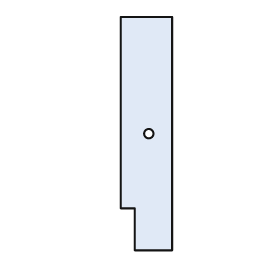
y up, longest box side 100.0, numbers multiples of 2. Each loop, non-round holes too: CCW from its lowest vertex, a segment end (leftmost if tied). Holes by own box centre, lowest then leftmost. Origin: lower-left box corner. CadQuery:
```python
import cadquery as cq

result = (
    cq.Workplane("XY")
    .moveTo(6.0, 0.0)
    .lineTo(22.0, 0.0)
    .lineTo(22.0, 100.0)
    .lineTo(0.0, 100.0)
    .lineTo(0.0, 18.0)
    .lineTo(6.0, 18.0)
    .close()
    .moveTo(12.0, 50.0)
    .circle(2.0)
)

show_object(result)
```